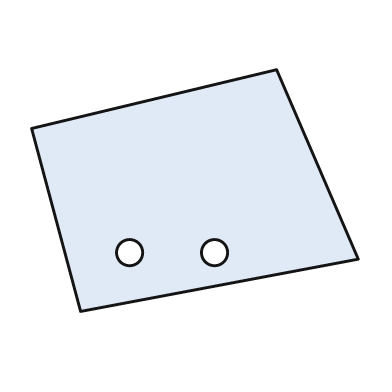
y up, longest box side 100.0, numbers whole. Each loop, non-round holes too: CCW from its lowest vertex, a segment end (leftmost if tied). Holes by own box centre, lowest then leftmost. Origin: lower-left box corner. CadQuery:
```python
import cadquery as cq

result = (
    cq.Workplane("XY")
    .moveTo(15.0, 0.0)
    .lineTo(100.0, 16.0)
    .lineTo(75.0, 74.0)
    .lineTo(0.0, 56.0)
    .close()
    .moveTo(30.0, 18.0)
    .circle(4.0)
    .moveTo(56.0, 18.0)
    .circle(4.0)
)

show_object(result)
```